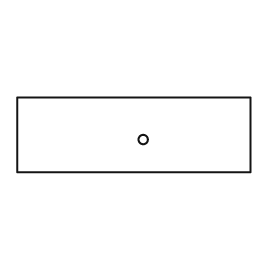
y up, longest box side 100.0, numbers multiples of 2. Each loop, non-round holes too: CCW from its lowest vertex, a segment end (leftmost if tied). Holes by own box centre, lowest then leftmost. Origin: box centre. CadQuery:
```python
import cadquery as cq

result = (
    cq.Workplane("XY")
    .moveTo(-50.0, -16.0)
    .lineTo(50.0, -16.0)
    .lineTo(50.0, 16.0)
    .lineTo(-50.0, 16.0)
    .close()
    .moveTo(4.0, -2.0)
    .circle(2.0)
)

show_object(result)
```